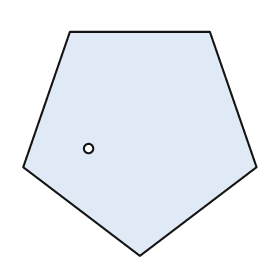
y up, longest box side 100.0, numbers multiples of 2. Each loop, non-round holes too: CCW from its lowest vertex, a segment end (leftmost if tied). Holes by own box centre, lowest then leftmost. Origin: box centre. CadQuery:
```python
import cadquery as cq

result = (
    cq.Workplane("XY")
    .moveTo(0.0, -48.0)
    .lineTo(50.0, -10.0)
    .lineTo(30.0, 48.0)
    .lineTo(-30.0, 48.0)
    .lineTo(-50.0, -10.0)
    .close()
    .moveTo(-22.0, -2.0)
    .circle(2.0)
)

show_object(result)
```